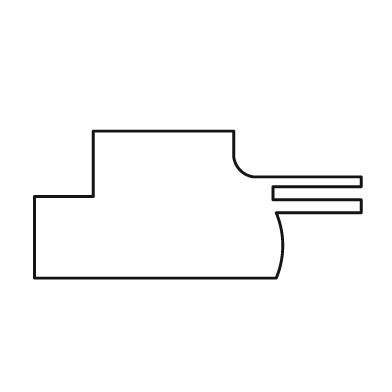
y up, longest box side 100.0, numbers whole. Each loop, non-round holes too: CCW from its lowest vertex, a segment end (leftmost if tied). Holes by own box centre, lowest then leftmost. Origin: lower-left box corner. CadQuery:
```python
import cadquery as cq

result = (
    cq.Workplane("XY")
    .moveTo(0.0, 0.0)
    .lineTo(74.0, 0.0)
    .threePointArc((76.0, 10.0), (74.0, 20.0))
    .lineTo(100.0, 20.0)
    .lineTo(100.0, 24.0)
    .lineTo(73.0, 24.0)
    .lineTo(73.0, 28.0)
    .lineTo(100.0, 28.0)
    .lineTo(100.0, 31.0)
    .lineTo(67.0, 31.0)
    .threePointArc((63.0, 33.0), (61.0, 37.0))
    .lineTo(61.0, 45.0)
    .lineTo(18.0, 45.0)
    .lineTo(18.0, 25.0)
    .lineTo(0.0, 25.0)
    .close()
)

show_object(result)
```